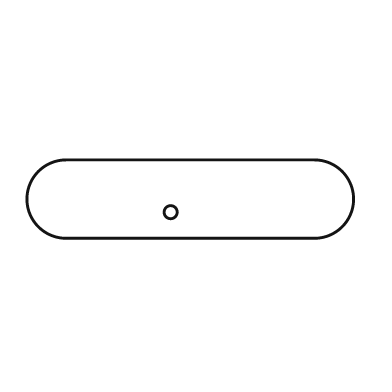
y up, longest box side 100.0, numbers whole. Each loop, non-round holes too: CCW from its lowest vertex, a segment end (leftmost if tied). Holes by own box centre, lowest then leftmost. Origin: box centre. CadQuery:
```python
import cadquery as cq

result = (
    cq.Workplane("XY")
    .moveTo(-38.0, -12.0)
    .lineTo(38.0, -12.0)
    .threePointArc((50.0, 0.0), (38.0, 12.0))
    .lineTo(-38.0, 12.0)
    .threePointArc((-50.0, 0.0), (-38.0, -12.0))
    .close()
    .moveTo(-6.0, -4.0)
    .circle(2.0)
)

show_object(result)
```